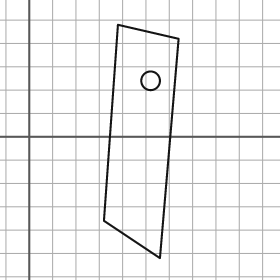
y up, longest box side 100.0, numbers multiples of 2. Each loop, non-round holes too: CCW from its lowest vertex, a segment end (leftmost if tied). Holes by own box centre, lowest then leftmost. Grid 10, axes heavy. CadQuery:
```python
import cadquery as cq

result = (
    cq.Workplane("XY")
    .moveTo(56.0, -52.0)
    .lineTo(64.0, 42.0)
    .lineTo(38.0, 48.0)
    .lineTo(32.0, -36.0)
    .close()
    .moveTo(52.0, 24.0)
    .circle(4.0)
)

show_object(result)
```